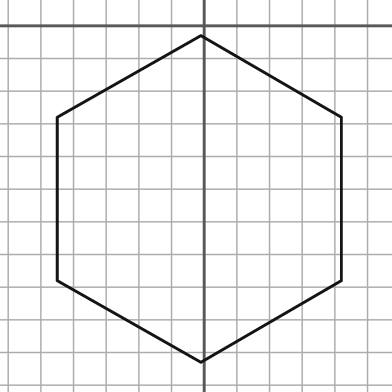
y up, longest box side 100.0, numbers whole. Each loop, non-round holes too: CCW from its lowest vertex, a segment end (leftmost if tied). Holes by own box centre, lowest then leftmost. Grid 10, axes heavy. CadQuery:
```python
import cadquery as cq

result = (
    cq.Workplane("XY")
    .moveTo(-1.0, -103.0)
    .lineTo(42.0, -78.0)
    .lineTo(42.0, -28.0)
    .lineTo(-1.0, -3.0)
    .lineTo(-45.0, -28.0)
    .lineTo(-45.0, -78.0)
    .close()
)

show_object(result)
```